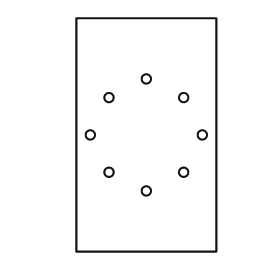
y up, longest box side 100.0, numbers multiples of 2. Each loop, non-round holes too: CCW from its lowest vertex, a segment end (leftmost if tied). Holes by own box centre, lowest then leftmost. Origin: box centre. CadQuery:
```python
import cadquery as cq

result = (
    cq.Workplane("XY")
    .moveTo(-30.0, -50.0)
    .lineTo(30.0, -50.0)
    .lineTo(30.0, 50.0)
    .lineTo(-30.0, 50.0)
    .close()
    .moveTo(0.0, -24.0)
    .circle(2.0)
    .moveTo(-16.0, -16.0)
    .circle(2.0)
    .moveTo(16.0, -16.0)
    .circle(2.0)
    .moveTo(-24.0, 0.0)
    .circle(2.0)
    .moveTo(24.0, 0.0)
    .circle(2.0)
    .moveTo(-16.0, 16.0)
    .circle(2.0)
    .moveTo(16.0, 16.0)
    .circle(2.0)
    .moveTo(0.0, 24.0)
    .circle(2.0)
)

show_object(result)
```